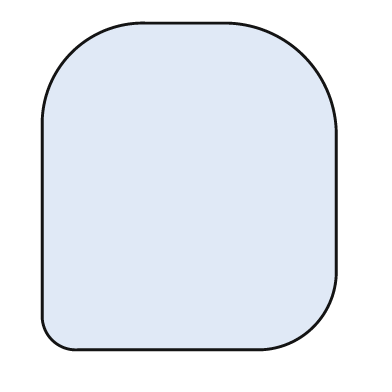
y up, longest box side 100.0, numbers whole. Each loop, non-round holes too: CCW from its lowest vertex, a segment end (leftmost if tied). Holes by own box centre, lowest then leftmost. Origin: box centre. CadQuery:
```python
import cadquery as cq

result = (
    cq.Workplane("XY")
    .moveTo(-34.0, -50.0)
    .lineTo(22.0, -50.0)
    .threePointArc((38.0, -43.0), (45.0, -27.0))
    .lineTo(45.0, 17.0)
    .threePointArc((35.0, 40.0), (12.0, 50.0))
    .lineTo(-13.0, 50.0)
    .threePointArc((-36.0, 41.0), (-45.0, 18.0))
    .lineTo(-45.0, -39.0)
    .threePointArc((-42.0, -47.0), (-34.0, -50.0))
    .close()
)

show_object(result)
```